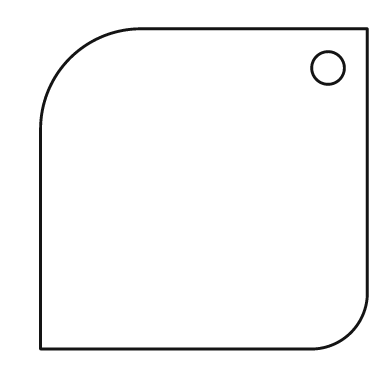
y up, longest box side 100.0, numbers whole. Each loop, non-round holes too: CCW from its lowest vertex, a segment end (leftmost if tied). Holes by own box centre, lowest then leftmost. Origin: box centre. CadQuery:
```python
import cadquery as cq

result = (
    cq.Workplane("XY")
    .moveTo(-50.0, -49.0)
    .lineTo(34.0, -49.0)
    .threePointArc((45.0, -44.0), (50.0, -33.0))
    .lineTo(50.0, 49.0)
    .lineTo(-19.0, 49.0)
    .threePointArc((-41.0, 40.0), (-50.0, 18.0))
    .close()
    .moveTo(38.0, 37.0)
    .circle(5.0)
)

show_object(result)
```